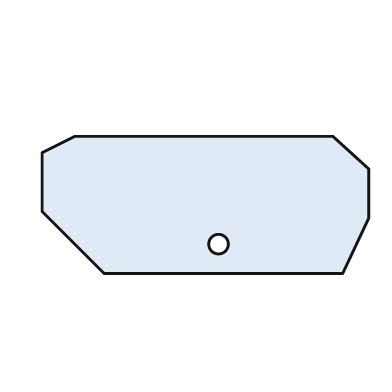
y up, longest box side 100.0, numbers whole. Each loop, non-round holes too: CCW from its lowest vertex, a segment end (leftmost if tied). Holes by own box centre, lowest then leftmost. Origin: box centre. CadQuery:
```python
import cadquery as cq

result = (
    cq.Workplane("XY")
    .moveTo(-31.0, -21.0)
    .lineTo(42.0, -21.0)
    .lineTo(50.0, -4.0)
    .lineTo(50.0, 11.0)
    .lineTo(39.0, 21.0)
    .lineTo(-40.0, 21.0)
    .lineTo(-50.0, 16.0)
    .lineTo(-50.0, -2.0)
    .close()
    .moveTo(4.0, -12.0)
    .circle(3.0)
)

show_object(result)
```